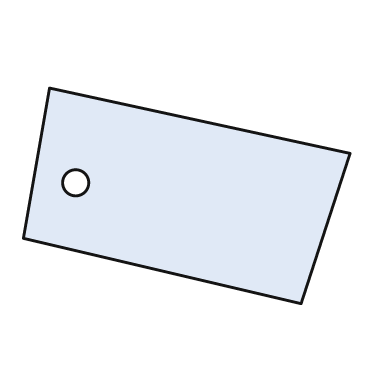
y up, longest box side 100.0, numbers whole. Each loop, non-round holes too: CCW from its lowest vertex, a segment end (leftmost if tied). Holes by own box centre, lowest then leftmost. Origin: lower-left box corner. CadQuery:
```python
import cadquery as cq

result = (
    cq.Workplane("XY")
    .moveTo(85.0, 0.0)
    .lineTo(100.0, 46.0)
    .lineTo(8.0, 66.0)
    .lineTo(0.0, 20.0)
    .close()
    .moveTo(16.0, 37.0)
    .circle(4.0)
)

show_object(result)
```